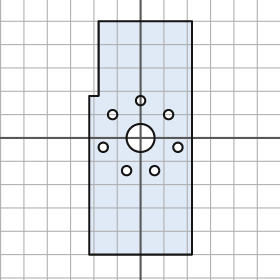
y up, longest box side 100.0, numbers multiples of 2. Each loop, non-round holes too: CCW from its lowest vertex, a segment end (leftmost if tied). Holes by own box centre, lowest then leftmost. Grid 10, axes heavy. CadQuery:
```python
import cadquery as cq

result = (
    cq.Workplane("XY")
    .moveTo(-22.0, -50.0)
    .lineTo(22.0, -50.0)
    .lineTo(22.0, 50.0)
    .lineTo(-18.0, 50.0)
    .lineTo(-18.0, 18.0)
    .lineTo(-22.0, 18.0)
    .close()
    .moveTo(-6.0, -14.0)
    .circle(2.0)
    .moveTo(6.0, -14.0)
    .circle(2.0)
    .moveTo(-16.0, -4.0)
    .circle(2.0)
    .moveTo(16.0, -4.0)
    .circle(2.0)
    .moveTo(0.0, 0.0)
    .circle(6.0)
    .moveTo(-12.0, 10.0)
    .circle(2.0)
    .moveTo(12.0, 10.0)
    .circle(2.0)
    .moveTo(0.0, 16.0)
    .circle(2.0)
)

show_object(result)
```